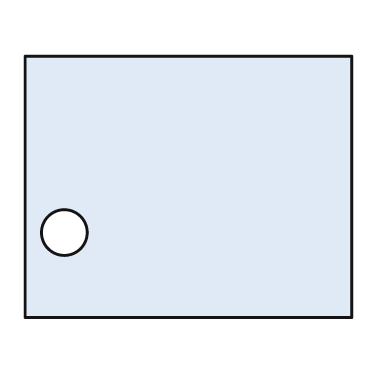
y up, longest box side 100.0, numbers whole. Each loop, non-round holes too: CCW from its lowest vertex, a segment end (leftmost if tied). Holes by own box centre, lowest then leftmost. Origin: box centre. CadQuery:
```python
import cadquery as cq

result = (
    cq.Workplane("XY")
    .moveTo(-50.0, -40.0)
    .lineTo(50.0, -40.0)
    .lineTo(50.0, 40.0)
    .lineTo(-50.0, 40.0)
    .close()
    .moveTo(-38.0, -14.0)
    .circle(7.0)
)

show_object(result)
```